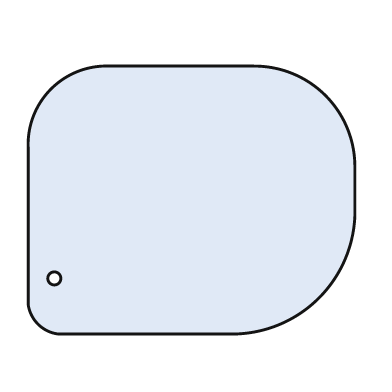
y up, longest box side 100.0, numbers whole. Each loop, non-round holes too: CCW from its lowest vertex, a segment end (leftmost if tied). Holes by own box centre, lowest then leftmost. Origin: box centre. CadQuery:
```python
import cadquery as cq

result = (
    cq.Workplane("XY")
    .moveTo(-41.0, -41.0)
    .lineTo(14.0, -41.0)
    .threePointArc((39.0, -30.0), (50.0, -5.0))
    .lineTo(50.0, 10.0)
    .threePointArc((41.0, 32.0), (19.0, 41.0))
    .lineTo(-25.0, 41.0)
    .threePointArc((-43.0, 34.0), (-50.0, 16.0))
    .lineTo(-50.0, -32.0)
    .threePointArc((-47.0, -38.0), (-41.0, -41.0))
    .close()
    .moveTo(-42.0, -24.0)
    .circle(2.0)
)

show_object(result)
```